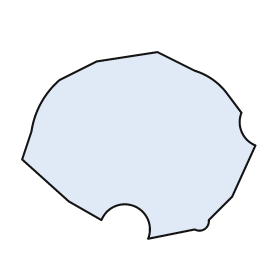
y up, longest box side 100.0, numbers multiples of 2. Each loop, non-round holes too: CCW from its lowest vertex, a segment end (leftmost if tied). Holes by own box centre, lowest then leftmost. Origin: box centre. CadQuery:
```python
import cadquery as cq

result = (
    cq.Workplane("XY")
    .moveTo(4.0, -40.0)
    .lineTo(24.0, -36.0)
    .threePointArc((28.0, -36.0), (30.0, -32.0))
    .lineTo(40.0, -22.0)
    .lineTo(50.0, 0.0)
    .threePointArc((44.0, 6.0), (44.0, 14.0))
    .lineTo(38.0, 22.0)
    .threePointArc((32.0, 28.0), (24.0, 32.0))
    .lineTo(8.0, 40.0)
    .lineTo(-18.0, 36.0)
    .lineTo(-34.0, 28.0)
    .threePointArc((-42.0, 18.0), (-46.0, 6.0))
    .lineTo(-50.0, -6.0)
    .lineTo(-30.0, -24.0)
    .lineTo(-16.0, -32.0)
    .threePointArc((-2.0, -26.0), (4.0, -40.0))
    .close()
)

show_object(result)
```